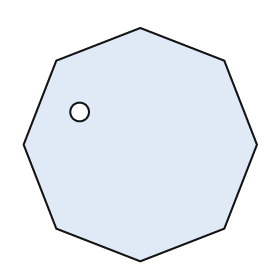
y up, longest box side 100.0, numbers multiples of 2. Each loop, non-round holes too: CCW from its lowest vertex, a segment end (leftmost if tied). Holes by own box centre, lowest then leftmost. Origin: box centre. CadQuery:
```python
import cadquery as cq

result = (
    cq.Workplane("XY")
    .moveTo(0.0, -50.0)
    .lineTo(36.0, -36.0)
    .lineTo(50.0, 0.0)
    .lineTo(36.0, 36.0)
    .lineTo(0.0, 50.0)
    .lineTo(-36.0, 36.0)
    .lineTo(-50.0, 0.0)
    .lineTo(-36.0, -36.0)
    .close()
    .moveTo(-26.0, 14.0)
    .circle(4.0)
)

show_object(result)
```